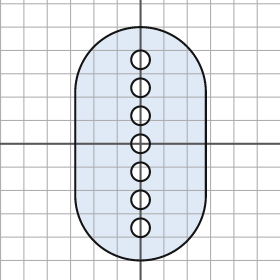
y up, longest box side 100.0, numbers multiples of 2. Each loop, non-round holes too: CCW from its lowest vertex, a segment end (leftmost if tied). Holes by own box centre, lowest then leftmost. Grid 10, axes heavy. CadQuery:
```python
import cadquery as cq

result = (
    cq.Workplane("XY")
    .moveTo(-28.0, -22.0)
    .threePointArc((0.0, -50.0), (28.0, -22.0))
    .lineTo(28.0, 22.0)
    .threePointArc((0.0, 50.0), (-28.0, 22.0))
    .close()
    .moveTo(0.0, -36.0)
    .circle(4.0)
    .moveTo(0.0, -24.0)
    .circle(4.0)
    .moveTo(0.0, -12.0)
    .circle(4.0)
    .moveTo(0.0, 0.0)
    .circle(4.0)
    .moveTo(0.0, 12.0)
    .circle(4.0)
    .moveTo(0.0, 24.0)
    .circle(4.0)
    .moveTo(0.0, 36.0)
    .circle(4.0)
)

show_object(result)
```